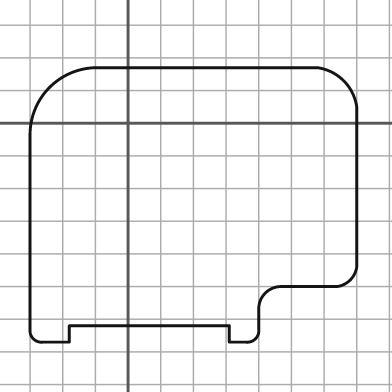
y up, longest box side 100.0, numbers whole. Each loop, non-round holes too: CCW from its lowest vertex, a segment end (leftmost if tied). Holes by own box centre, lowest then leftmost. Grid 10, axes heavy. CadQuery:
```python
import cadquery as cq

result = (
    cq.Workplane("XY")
    .moveTo(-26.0, -67.0)
    .lineTo(-18.0, -67.0)
    .lineTo(-18.0, -62.0)
    .lineTo(31.0, -62.0)
    .lineTo(31.0, -67.0)
    .lineTo(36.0, -67.0)
    .threePointArc((39.0, -66.0), (40.0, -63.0))
    .lineTo(40.0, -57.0)
    .threePointArc((42.0, -52.0), (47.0, -50.0))
    .lineTo(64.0, -50.0)
    .threePointArc((68.0, -48.0), (70.0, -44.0))
    .lineTo(70.0, 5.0)
    .threePointArc((66.0, 13.0), (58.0, 17.0))
    .lineTo(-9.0, 17.0)
    .threePointArc((-24.0, 11.0), (-30.0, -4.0))
    .lineTo(-30.0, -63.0)
    .threePointArc((-29.0, -66.0), (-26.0, -67.0))
    .close()
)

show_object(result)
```